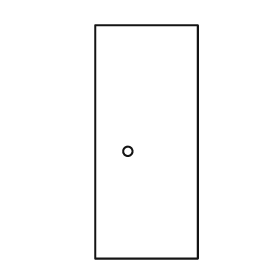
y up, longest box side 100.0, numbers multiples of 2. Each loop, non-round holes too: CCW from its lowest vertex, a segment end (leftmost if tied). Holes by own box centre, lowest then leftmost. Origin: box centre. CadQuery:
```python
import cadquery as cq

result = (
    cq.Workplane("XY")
    .moveTo(-22.0, -50.0)
    .lineTo(22.0, -50.0)
    .lineTo(22.0, 50.0)
    .lineTo(-22.0, 50.0)
    .close()
    .moveTo(-8.0, -4.0)
    .circle(2.0)
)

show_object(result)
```